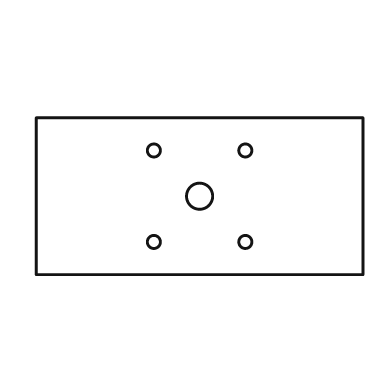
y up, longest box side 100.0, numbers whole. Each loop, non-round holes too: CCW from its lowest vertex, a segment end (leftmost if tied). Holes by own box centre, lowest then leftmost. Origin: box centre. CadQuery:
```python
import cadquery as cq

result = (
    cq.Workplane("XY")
    .moveTo(-50.0, -24.0)
    .lineTo(50.0, -24.0)
    .lineTo(50.0, 24.0)
    .lineTo(-50.0, 24.0)
    .close()
    .moveTo(-14.0, -14.0)
    .circle(2.0)
    .moveTo(14.0, -14.0)
    .circle(2.0)
    .moveTo(0.0, 0.0)
    .circle(4.0)
    .moveTo(-14.0, 14.0)
    .circle(2.0)
    .moveTo(14.0, 14.0)
    .circle(2.0)
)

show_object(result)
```